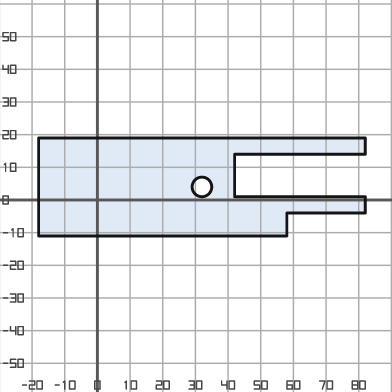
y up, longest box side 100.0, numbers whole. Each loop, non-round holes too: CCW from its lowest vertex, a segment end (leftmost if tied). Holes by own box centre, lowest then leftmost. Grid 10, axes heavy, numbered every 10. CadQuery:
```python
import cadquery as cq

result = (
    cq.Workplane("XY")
    .moveTo(-18.0, -11.0)
    .lineTo(58.0, -11.0)
    .lineTo(58.0, -4.0)
    .lineTo(82.0, -4.0)
    .lineTo(82.0, 1.0)
    .lineTo(42.0, 1.0)
    .lineTo(42.0, 14.0)
    .lineTo(82.0, 14.0)
    .lineTo(82.0, 19.0)
    .lineTo(-18.0, 19.0)
    .close()
    .moveTo(32.0, 4.0)
    .circle(3.0)
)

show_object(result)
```